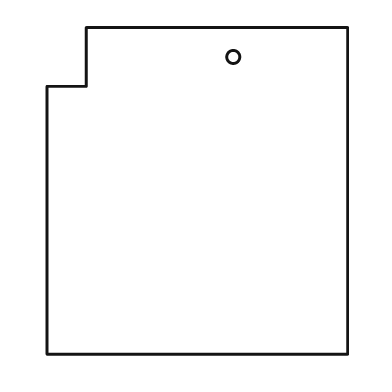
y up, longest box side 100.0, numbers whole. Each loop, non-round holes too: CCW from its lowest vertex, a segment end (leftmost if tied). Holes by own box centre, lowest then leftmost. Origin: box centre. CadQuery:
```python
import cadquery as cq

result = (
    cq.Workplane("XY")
    .moveTo(-46.0, -50.0)
    .lineTo(46.0, -50.0)
    .lineTo(46.0, 50.0)
    .lineTo(-34.0, 50.0)
    .lineTo(-34.0, 32.0)
    .lineTo(-46.0, 32.0)
    .close()
    .moveTo(11.0, 41.0)
    .circle(2.0)
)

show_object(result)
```